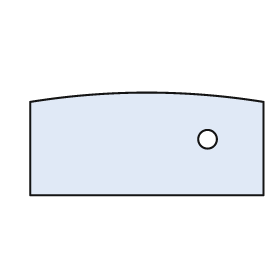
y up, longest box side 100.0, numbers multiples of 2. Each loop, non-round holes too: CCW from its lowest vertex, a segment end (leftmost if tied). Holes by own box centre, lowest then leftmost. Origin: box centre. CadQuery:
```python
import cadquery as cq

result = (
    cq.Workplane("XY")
    .moveTo(-50.0, -22.0)
    .lineTo(50.0, -22.0)
    .lineTo(50.0, 18.0)
    .threePointArc((0.0, 22.0), (-50.0, 18.0))
    .close()
    .moveTo(26.0, 2.0)
    .circle(4.0)
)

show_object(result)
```